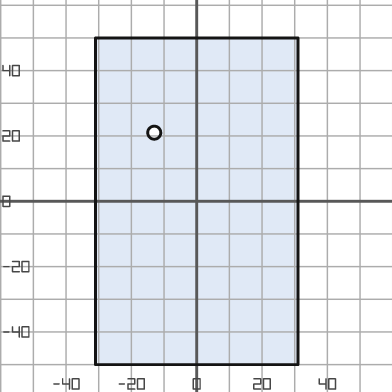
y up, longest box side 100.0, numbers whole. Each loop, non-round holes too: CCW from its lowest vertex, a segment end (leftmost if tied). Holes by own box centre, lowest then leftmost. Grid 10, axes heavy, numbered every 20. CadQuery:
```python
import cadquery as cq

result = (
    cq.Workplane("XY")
    .moveTo(-31.0, -50.0)
    .lineTo(31.0, -50.0)
    .lineTo(31.0, 50.0)
    .lineTo(-31.0, 50.0)
    .close()
    .moveTo(-13.0, 21.0)
    .circle(2.0)
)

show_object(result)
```